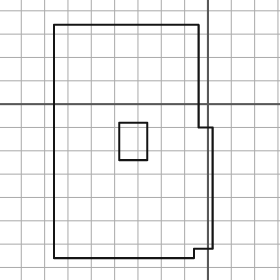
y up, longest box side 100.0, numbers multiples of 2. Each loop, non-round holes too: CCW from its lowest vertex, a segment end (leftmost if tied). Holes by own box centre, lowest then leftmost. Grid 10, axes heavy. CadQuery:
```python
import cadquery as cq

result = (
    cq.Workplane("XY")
    .moveTo(-66.0, -66.0)
    .lineTo(-6.0, -66.0)
    .lineTo(-6.0, -62.0)
    .lineTo(2.0, -62.0)
    .lineTo(2.0, -10.0)
    .lineTo(-4.0, -10.0)
    .lineTo(-4.0, 34.0)
    .lineTo(-66.0, 34.0)
    .close()
    .moveTo(-38.0, -24.0)
    .lineTo(-26.0, -24.0)
    .lineTo(-26.0, -8.0)
    .lineTo(-38.0, -8.0)
    .close()
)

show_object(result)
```